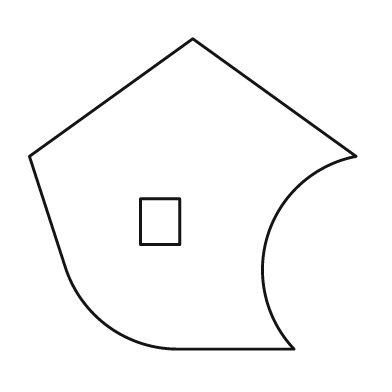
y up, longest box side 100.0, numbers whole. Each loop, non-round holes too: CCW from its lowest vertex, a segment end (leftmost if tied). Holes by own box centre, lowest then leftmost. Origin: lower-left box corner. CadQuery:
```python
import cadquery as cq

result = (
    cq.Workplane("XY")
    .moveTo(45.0, 0.0)
    .lineTo(81.0, 0.0)
    .threePointArc((73.0, 35.0), (100.0, 59.0))
    .lineTo(50.0, 95.0)
    .lineTo(0.0, 59.0)
    .lineTo(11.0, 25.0)
    .threePointArc((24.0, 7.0), (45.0, 0.0))
    .close()
    .moveTo(34.0, 32.0)
    .lineTo(46.0, 32.0)
    .lineTo(46.0, 46.0)
    .lineTo(34.0, 46.0)
    .close()
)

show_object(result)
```